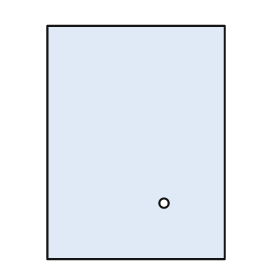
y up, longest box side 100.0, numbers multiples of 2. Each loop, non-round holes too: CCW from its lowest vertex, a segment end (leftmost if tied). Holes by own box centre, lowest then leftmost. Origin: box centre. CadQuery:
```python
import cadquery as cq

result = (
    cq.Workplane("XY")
    .moveTo(-38.0, -50.0)
    .lineTo(38.0, -50.0)
    .lineTo(38.0, 50.0)
    .lineTo(-38.0, 50.0)
    .close()
    .moveTo(12.0, -26.0)
    .circle(2.0)
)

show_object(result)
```